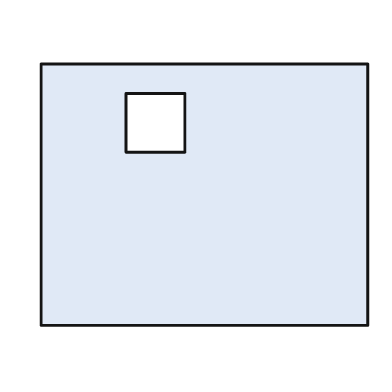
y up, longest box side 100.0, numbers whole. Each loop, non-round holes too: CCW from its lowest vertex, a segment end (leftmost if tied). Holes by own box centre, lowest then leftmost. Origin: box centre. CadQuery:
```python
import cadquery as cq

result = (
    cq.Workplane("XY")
    .moveTo(-50.0, -40.0)
    .lineTo(50.0, -40.0)
    .lineTo(50.0, 40.0)
    .lineTo(-50.0, 40.0)
    .close()
    .moveTo(-24.0, 13.0)
    .lineTo(-6.0, 13.0)
    .lineTo(-6.0, 31.0)
    .lineTo(-24.0, 31.0)
    .close()
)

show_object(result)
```